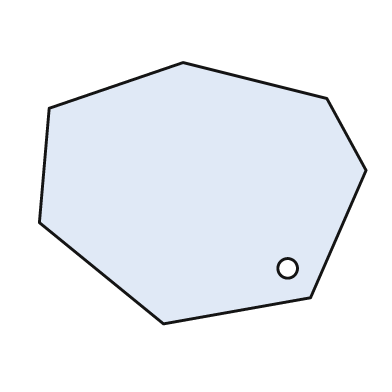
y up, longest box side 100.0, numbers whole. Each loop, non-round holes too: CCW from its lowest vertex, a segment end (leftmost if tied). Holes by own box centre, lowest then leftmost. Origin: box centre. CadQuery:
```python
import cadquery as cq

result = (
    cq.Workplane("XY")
    .moveTo(-12.0, -40.0)
    .lineTo(33.0, -32.0)
    .lineTo(50.0, 7.0)
    .lineTo(38.0, 29.0)
    .lineTo(-6.0, 40.0)
    .lineTo(-47.0, 26.0)
    .lineTo(-50.0, -9.0)
    .close()
    .moveTo(26.0, -23.0)
    .circle(3.0)
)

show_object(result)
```